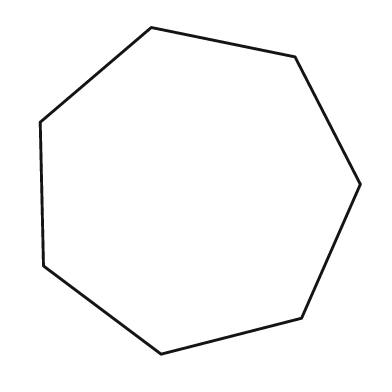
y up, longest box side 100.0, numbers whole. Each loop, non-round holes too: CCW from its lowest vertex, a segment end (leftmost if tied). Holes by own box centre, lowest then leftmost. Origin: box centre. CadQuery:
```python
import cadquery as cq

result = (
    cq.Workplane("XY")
    .moveTo(-12.0, -50.0)
    .lineTo(31.0, -39.0)
    .lineTo(49.0, 2.0)
    .lineTo(29.0, 41.0)
    .lineTo(-15.0, 50.0)
    .lineTo(-49.0, 21.0)
    .lineTo(-48.0, -23.0)
    .close()
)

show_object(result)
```